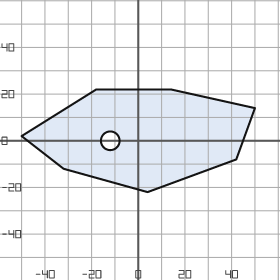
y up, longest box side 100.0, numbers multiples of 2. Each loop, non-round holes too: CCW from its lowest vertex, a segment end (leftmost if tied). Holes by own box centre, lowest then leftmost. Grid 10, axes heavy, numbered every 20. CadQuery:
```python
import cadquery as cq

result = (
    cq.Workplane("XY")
    .moveTo(4.0, -22.0)
    .lineTo(42.0, -8.0)
    .lineTo(50.0, 14.0)
    .lineTo(14.0, 22.0)
    .lineTo(-18.0, 22.0)
    .lineTo(-50.0, 2.0)
    .lineTo(-32.0, -12.0)
    .close()
    .moveTo(-12.0, 0.0)
    .circle(4.0)
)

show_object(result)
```